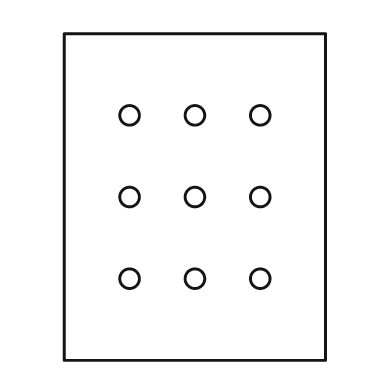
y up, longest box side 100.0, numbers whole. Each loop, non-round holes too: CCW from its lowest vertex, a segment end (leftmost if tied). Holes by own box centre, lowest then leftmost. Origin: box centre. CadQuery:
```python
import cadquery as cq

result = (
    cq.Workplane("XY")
    .moveTo(-40.0, -50.0)
    .lineTo(40.0, -50.0)
    .lineTo(40.0, 50.0)
    .lineTo(-40.0, 50.0)
    .close()
    .moveTo(-20.0, -25.0)
    .circle(3.0)
    .moveTo(0.0, -25.0)
    .circle(3.0)
    .moveTo(20.0, -25.0)
    .circle(3.0)
    .moveTo(-20.0, 0.0)
    .circle(3.0)
    .moveTo(0.0, 0.0)
    .circle(3.0)
    .moveTo(20.0, 0.0)
    .circle(3.0)
    .moveTo(-20.0, 25.0)
    .circle(3.0)
    .moveTo(0.0, 25.0)
    .circle(3.0)
    .moveTo(20.0, 25.0)
    .circle(3.0)
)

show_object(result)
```